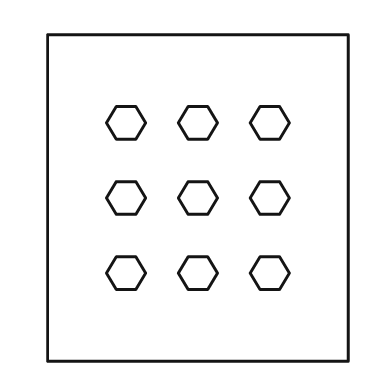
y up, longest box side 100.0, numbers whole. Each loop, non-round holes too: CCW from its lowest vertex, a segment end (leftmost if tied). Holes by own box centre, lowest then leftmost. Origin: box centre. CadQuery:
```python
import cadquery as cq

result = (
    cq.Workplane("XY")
    .moveTo(-46.0, -50.0)
    .lineTo(46.0, -50.0)
    .lineTo(46.0, 50.0)
    .lineTo(-46.0, 50.0)
    .close()
    .moveTo(-25.0, -28.0)
    .lineTo(-19.0, -28.0)
    .lineTo(-16.0, -23.0)
    .lineTo(-19.0, -18.0)
    .lineTo(-25.0, -18.0)
    .lineTo(-28.0, -23.0)
    .close()
    .moveTo(-3.0, -28.0)
    .lineTo(3.0, -28.0)
    .lineTo(6.0, -23.0)
    .lineTo(3.0, -18.0)
    .lineTo(-3.0, -18.0)
    .lineTo(-6.0, -23.0)
    .close()
    .moveTo(19.0, -28.0)
    .lineTo(25.0, -28.0)
    .lineTo(28.0, -23.0)
    .lineTo(25.0, -18.0)
    .lineTo(19.0, -18.0)
    .lineTo(16.0, -23.0)
    .close()
    .moveTo(-25.0, -5.0)
    .lineTo(-19.0, -5.0)
    .lineTo(-16.0, 0.0)
    .lineTo(-19.0, 5.0)
    .lineTo(-25.0, 5.0)
    .lineTo(-28.0, 0.0)
    .close()
    .moveTo(-3.0, -5.0)
    .lineTo(3.0, -5.0)
    .lineTo(6.0, 0.0)
    .lineTo(3.0, 5.0)
    .lineTo(-3.0, 5.0)
    .lineTo(-6.0, 0.0)
    .close()
    .moveTo(19.0, -5.0)
    .lineTo(25.0, -5.0)
    .lineTo(28.0, 0.0)
    .lineTo(25.0, 5.0)
    .lineTo(19.0, 5.0)
    .lineTo(16.0, 0.0)
    .close()
    .moveTo(-25.0, 18.0)
    .lineTo(-19.0, 18.0)
    .lineTo(-16.0, 23.0)
    .lineTo(-19.0, 28.0)
    .lineTo(-25.0, 28.0)
    .lineTo(-28.0, 23.0)
    .close()
    .moveTo(-3.0, 18.0)
    .lineTo(3.0, 18.0)
    .lineTo(6.0, 23.0)
    .lineTo(3.0, 28.0)
    .lineTo(-3.0, 28.0)
    .lineTo(-6.0, 23.0)
    .close()
    .moveTo(19.0, 18.0)
    .lineTo(25.0, 18.0)
    .lineTo(28.0, 23.0)
    .lineTo(25.0, 28.0)
    .lineTo(19.0, 28.0)
    .lineTo(16.0, 23.0)
    .close()
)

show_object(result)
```